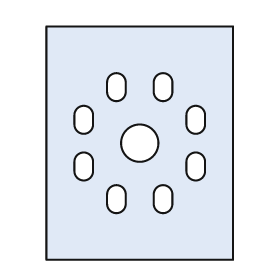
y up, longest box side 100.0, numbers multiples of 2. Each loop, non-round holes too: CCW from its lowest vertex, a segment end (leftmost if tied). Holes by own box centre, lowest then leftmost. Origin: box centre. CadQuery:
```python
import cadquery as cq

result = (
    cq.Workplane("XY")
    .moveTo(-40.0, -50.0)
    .lineTo(40.0, -50.0)
    .lineTo(40.0, 50.0)
    .lineTo(-40.0, 50.0)
    .close()
    .moveTo(-14.0, -26.0)
    .threePointArc((-10.0, -30.0), (-6.0, -26.0))
    .lineTo(-6.0, -22.0)
    .threePointArc((-10.0, -18.0), (-14.0, -22.0))
    .close()
    .moveTo(6.0, -26.0)
    .threePointArc((10.0, -30.0), (14.0, -26.0))
    .lineTo(14.0, -22.0)
    .threePointArc((10.0, -18.0), (6.0, -22.0))
    .close()
    .moveTo(-28.0, -12.0)
    .threePointArc((-24.0, -16.0), (-20.0, -12.0))
    .lineTo(-20.0, -8.0)
    .threePointArc((-24.0, -4.0), (-28.0, -8.0))
    .close()
    .moveTo(20.0, -12.0)
    .threePointArc((24.0, -16.0), (28.0, -12.0))
    .lineTo(28.0, -8.0)
    .threePointArc((24.0, -4.0), (20.0, -8.0))
    .close()
    .moveTo(0.0, 0.0)
    .circle(8.0)
    .moveTo(-28.0, 8.0)
    .threePointArc((-24.0, 4.0), (-20.0, 8.0))
    .lineTo(-20.0, 12.0)
    .threePointArc((-24.0, 16.0), (-28.0, 12.0))
    .close()
    .moveTo(20.0, 8.0)
    .threePointArc((24.0, 4.0), (28.0, 8.0))
    .lineTo(28.0, 12.0)
    .threePointArc((24.0, 16.0), (20.0, 12.0))
    .close()
    .moveTo(-14.0, 22.0)
    .threePointArc((-10.0, 18.0), (-6.0, 22.0))
    .lineTo(-6.0, 26.0)
    .threePointArc((-10.0, 30.0), (-14.0, 26.0))
    .close()
    .moveTo(6.0, 22.0)
    .threePointArc((10.0, 18.0), (14.0, 22.0))
    .lineTo(14.0, 26.0)
    .threePointArc((10.0, 30.0), (6.0, 26.0))
    .close()
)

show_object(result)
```